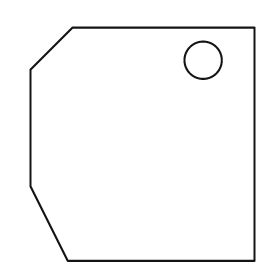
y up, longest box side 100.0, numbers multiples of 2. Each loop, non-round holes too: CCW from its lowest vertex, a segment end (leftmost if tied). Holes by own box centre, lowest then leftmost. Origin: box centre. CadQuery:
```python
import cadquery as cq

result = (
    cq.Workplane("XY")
    .moveTo(-32.0, -50.0)
    .lineTo(48.0, -50.0)
    .lineTo(48.0, 50.0)
    .lineTo(-30.0, 50.0)
    .lineTo(-48.0, 32.0)
    .lineTo(-48.0, -18.0)
    .close()
    .moveTo(26.0, 36.0)
    .circle(8.0)
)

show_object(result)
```